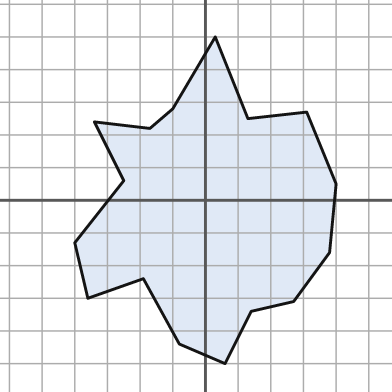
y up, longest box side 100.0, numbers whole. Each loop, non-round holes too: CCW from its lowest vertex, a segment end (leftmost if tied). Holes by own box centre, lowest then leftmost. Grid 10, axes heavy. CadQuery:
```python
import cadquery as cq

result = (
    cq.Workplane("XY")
    .moveTo(6.0, -50.0)
    .lineTo(14.0, -34.0)
    .lineTo(27.0, -31.0)
    .lineTo(38.0, -16.0)
    .lineTo(40.0, 5.0)
    .lineTo(31.0, 27.0)
    .lineTo(13.0, 25.0)
    .lineTo(3.0, 50.0)
    .lineTo(-10.0, 28.0)
    .lineTo(-17.0, 22.0)
    .lineTo(-34.0, 24.0)
    .lineTo(-25.0, 6.0)
    .lineTo(-40.0, -13.0)
    .lineTo(-36.0, -30.0)
    .lineTo(-19.0, -24.0)
    .lineTo(-8.0, -44.0)
    .close()
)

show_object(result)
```